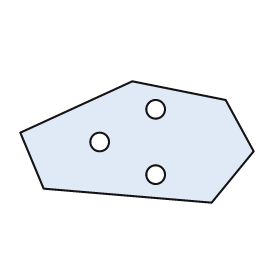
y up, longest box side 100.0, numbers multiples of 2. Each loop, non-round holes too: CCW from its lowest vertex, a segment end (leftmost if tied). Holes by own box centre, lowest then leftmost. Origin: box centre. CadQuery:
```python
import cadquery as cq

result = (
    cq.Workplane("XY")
    .moveTo(32.0, -26.0)
    .lineTo(50.0, -4.0)
    .lineTo(38.0, 18.0)
    .lineTo(-2.0, 26.0)
    .lineTo(-50.0, 4.0)
    .lineTo(-40.0, -20.0)
    .close()
    .moveTo(8.0, -14.0)
    .circle(4.0)
    .moveTo(-16.0, 0.0)
    .circle(4.0)
    .moveTo(8.0, 14.0)
    .circle(4.0)
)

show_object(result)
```